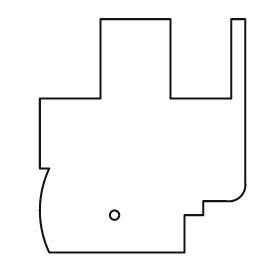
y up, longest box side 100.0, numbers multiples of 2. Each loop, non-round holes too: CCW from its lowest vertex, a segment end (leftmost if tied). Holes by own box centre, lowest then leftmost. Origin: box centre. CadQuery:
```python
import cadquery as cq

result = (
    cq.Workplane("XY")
    .moveTo(-40.0, -50.0)
    .lineTo(18.0, -50.0)
    .lineTo(18.0, -34.0)
    .lineTo(26.0, -34.0)
    .lineTo(26.0, -28.0)
    .lineTo(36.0, -28.0)
    .threePointArc((42.0, -26.0), (44.0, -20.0))
    .lineTo(44.0, 50.0)
    .lineTo(38.0, 50.0)
    .lineTo(38.0, 16.0)
    .lineTo(12.0, 16.0)
    .lineTo(12.0, 50.0)
    .lineTo(-18.0, 50.0)
    .lineTo(-18.0, 16.0)
    .lineTo(-44.0, 16.0)
    .lineTo(-44.0, -14.0)
    .lineTo(-40.0, -14.0)
    .threePointArc((-44.0, -32.0), (-40.0, -50.0))
    .close()
    .moveTo(-12.0, -34.0)
    .circle(2.0)
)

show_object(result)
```